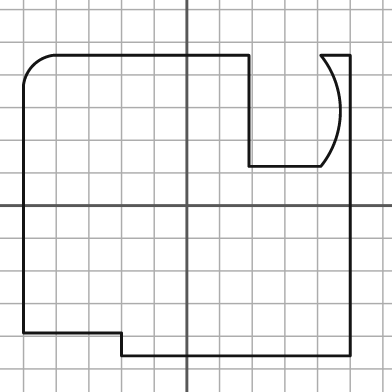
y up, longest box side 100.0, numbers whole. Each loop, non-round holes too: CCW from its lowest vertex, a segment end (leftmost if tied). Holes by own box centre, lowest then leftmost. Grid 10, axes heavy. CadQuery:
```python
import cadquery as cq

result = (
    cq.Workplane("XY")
    .moveTo(-20.0, -46.0)
    .lineTo(50.0, -46.0)
    .lineTo(50.0, 46.0)
    .lineTo(41.0, 46.0)
    .threePointArc((47.0, 29.0), (41.0, 12.0))
    .lineTo(19.0, 12.0)
    .lineTo(19.0, 46.0)
    .lineTo(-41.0, 46.0)
    .threePointArc((-47.0, 43.0), (-50.0, 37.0))
    .lineTo(-50.0, -39.0)
    .lineTo(-20.0, -39.0)
    .close()
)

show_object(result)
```